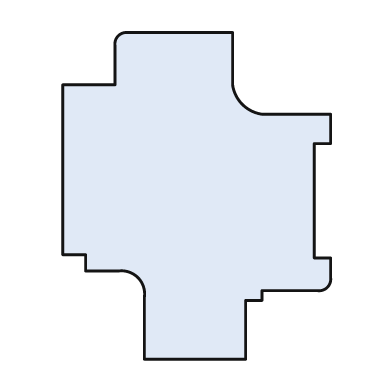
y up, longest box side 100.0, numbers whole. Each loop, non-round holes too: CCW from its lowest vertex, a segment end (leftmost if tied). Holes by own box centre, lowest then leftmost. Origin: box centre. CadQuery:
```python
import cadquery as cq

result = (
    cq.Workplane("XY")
    .moveTo(-16.0, -50.0)
    .lineTo(15.0, -50.0)
    .lineTo(15.0, -32.0)
    .lineTo(20.0, -32.0)
    .lineTo(20.0, -29.0)
    .lineTo(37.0, -29.0)
    .threePointArc((40.0, -28.0), (41.0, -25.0))
    .lineTo(41.0, -19.0)
    .lineTo(36.0, -19.0)
    .lineTo(36.0, 16.0)
    .lineTo(41.0, 16.0)
    .lineTo(41.0, 25.0)
    .lineTo(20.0, 25.0)
    .threePointArc((14.0, 28.0), (11.0, 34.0))
    .lineTo(11.0, 50.0)
    .lineTo(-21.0, 50.0)
    .threePointArc((-24.0, 49.0), (-25.0, 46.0))
    .lineTo(-25.0, 34.0)
    .lineTo(-41.0, 34.0)
    .lineTo(-41.0, -18.0)
    .lineTo(-34.0, -18.0)
    .lineTo(-34.0, -23.0)
    .lineTo(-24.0, -23.0)
    .threePointArc((-18.0, -25.0), (-16.0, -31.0))
    .close()
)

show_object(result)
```